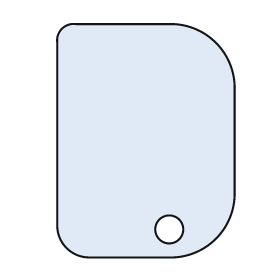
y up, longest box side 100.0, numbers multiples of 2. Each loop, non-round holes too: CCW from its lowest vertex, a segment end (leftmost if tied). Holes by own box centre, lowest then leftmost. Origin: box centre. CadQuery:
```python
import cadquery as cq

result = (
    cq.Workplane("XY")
    .moveTo(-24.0, -50.0)
    .lineTo(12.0, -50.0)
    .threePointArc((30.0, -42.0), (38.0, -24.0))
    .lineTo(38.0, 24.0)
    .threePointArc((30.0, 42.0), (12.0, 50.0))
    .lineTo(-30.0, 50.0)
    .threePointArc((-36.0, 48.0), (-38.0, 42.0))
    .lineTo(-38.0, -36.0)
    .threePointArc((-34.0, -46.0), (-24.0, -50.0))
    .close()
    .moveTo(10.0, -38.0)
    .circle(6.0)
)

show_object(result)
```